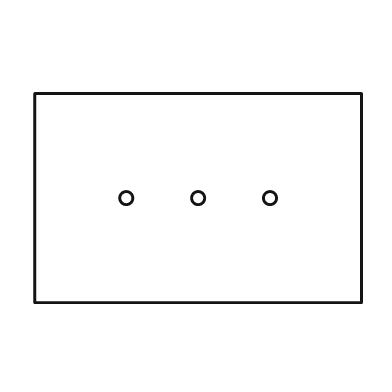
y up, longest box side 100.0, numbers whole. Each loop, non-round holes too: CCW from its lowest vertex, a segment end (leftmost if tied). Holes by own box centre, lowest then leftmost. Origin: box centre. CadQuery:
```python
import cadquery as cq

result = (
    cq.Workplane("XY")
    .moveTo(-50.0, -32.0)
    .lineTo(50.0, -32.0)
    .lineTo(50.0, 32.0)
    .lineTo(-50.0, 32.0)
    .close()
    .moveTo(-22.0, 0.0)
    .circle(2.0)
    .moveTo(0.0, 0.0)
    .circle(2.0)
    .moveTo(22.0, 0.0)
    .circle(2.0)
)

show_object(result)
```